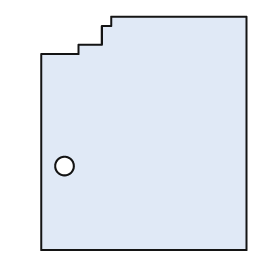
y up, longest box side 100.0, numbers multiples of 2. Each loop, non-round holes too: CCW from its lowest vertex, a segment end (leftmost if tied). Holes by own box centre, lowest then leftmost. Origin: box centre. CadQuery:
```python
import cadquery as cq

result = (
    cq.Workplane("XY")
    .moveTo(-44.0, -50.0)
    .lineTo(44.0, -50.0)
    .lineTo(44.0, 50.0)
    .lineTo(-14.0, 50.0)
    .lineTo(-14.0, 46.0)
    .lineTo(-18.0, 46.0)
    .lineTo(-18.0, 38.0)
    .lineTo(-28.0, 38.0)
    .lineTo(-28.0, 34.0)
    .lineTo(-44.0, 34.0)
    .close()
    .moveTo(-34.0, -14.0)
    .circle(4.0)
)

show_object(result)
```